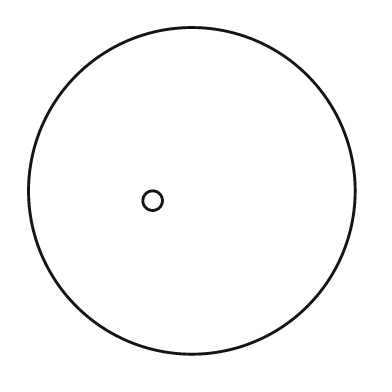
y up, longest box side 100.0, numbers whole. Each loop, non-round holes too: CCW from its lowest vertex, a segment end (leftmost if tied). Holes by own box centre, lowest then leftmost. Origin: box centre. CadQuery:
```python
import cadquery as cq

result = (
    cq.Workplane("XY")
    .moveTo(0.0, 0.0)
    .circle(50.0)
    .moveTo(-12.0, -3.0)
    .circle(3.0)
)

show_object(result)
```